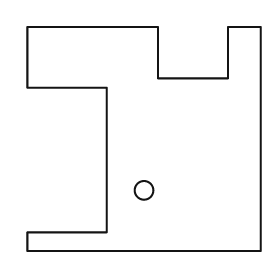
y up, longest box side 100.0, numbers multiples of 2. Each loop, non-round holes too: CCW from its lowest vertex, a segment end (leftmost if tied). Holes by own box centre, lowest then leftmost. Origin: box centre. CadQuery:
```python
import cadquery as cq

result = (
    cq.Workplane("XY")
    .moveTo(-50.0, -48.0)
    .lineTo(50.0, -48.0)
    .lineTo(50.0, 48.0)
    .lineTo(36.0, 48.0)
    .lineTo(36.0, 26.0)
    .lineTo(6.0, 26.0)
    .lineTo(6.0, 48.0)
    .lineTo(-50.0, 48.0)
    .lineTo(-50.0, 22.0)
    .lineTo(-16.0, 22.0)
    .lineTo(-16.0, -40.0)
    .lineTo(-50.0, -40.0)
    .close()
    .moveTo(0.0, -22.0)
    .circle(4.0)
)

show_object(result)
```